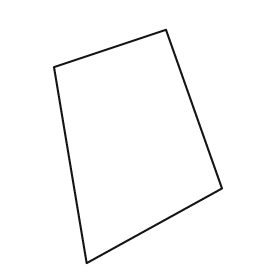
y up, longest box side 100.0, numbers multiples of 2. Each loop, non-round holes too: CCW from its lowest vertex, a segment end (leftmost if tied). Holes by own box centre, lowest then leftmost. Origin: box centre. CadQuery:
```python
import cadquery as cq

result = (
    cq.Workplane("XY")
    .moveTo(-22.0, -50.0)
    .lineTo(36.0, -18.0)
    .lineTo(12.0, 50.0)
    .lineTo(-36.0, 34.0)
    .close()
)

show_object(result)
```